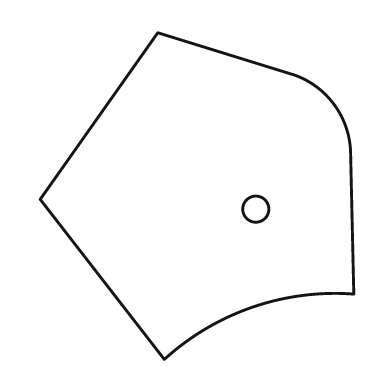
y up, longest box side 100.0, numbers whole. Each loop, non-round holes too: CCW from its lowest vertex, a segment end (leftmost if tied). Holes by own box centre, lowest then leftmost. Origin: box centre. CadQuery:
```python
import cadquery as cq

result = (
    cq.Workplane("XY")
    .moveTo(-10.0, -50.0)
    .threePointArc((17.0, -34.0), (48.0, -30.0))
    .lineTo(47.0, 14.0)
    .threePointArc((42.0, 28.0), (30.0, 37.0))
    .lineTo(-12.0, 50.0)
    .lineTo(-48.0, -1.0)
    .close()
    .moveTo(18.0, -4.0)
    .circle(4.0)
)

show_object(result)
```